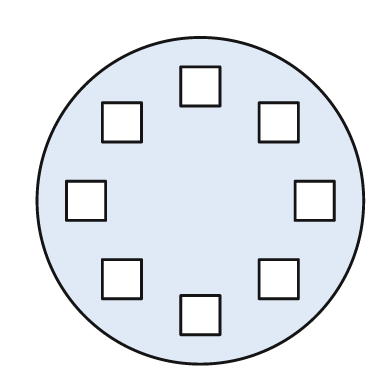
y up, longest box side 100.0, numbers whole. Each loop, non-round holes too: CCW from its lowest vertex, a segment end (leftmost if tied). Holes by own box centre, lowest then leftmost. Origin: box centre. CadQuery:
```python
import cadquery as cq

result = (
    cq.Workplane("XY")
    .moveTo(0.0, 0.0)
    .circle(50.0)
    .moveTo(-6.0, -41.0)
    .lineTo(6.0, -41.0)
    .lineTo(6.0, -29.0)
    .lineTo(-6.0, -29.0)
    .close()
    .moveTo(-30.0, -30.0)
    .lineTo(-18.0, -30.0)
    .lineTo(-18.0, -18.0)
    .lineTo(-30.0, -18.0)
    .close()
    .moveTo(18.0, -30.0)
    .lineTo(30.0, -30.0)
    .lineTo(30.0, -18.0)
    .lineTo(18.0, -18.0)
    .close()
    .moveTo(-41.0, -6.0)
    .lineTo(-29.0, -6.0)
    .lineTo(-29.0, 6.0)
    .lineTo(-41.0, 6.0)
    .close()
    .moveTo(29.0, -6.0)
    .lineTo(41.0, -6.0)
    .lineTo(41.0, 6.0)
    .lineTo(29.0, 6.0)
    .close()
    .moveTo(-30.0, 18.0)
    .lineTo(-18.0, 18.0)
    .lineTo(-18.0, 30.0)
    .lineTo(-30.0, 30.0)
    .close()
    .moveTo(18.0, 18.0)
    .lineTo(30.0, 18.0)
    .lineTo(30.0, 30.0)
    .lineTo(18.0, 30.0)
    .close()
    .moveTo(-6.0, 29.0)
    .lineTo(6.0, 29.0)
    .lineTo(6.0, 41.0)
    .lineTo(-6.0, 41.0)
    .close()
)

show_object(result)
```